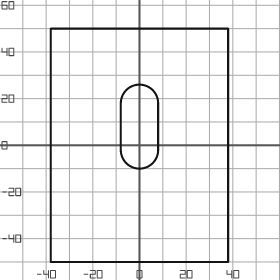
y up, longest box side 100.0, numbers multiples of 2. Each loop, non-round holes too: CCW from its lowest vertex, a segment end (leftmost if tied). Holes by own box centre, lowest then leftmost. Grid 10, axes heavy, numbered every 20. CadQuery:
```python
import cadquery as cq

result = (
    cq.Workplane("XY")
    .moveTo(-38.0, -50.0)
    .lineTo(38.0, -50.0)
    .lineTo(38.0, 50.0)
    .lineTo(-38.0, 50.0)
    .close()
    .moveTo(-8.0, -2.0)
    .threePointArc((0.0, -10.0), (8.0, -2.0))
    .lineTo(8.0, 18.0)
    .threePointArc((0.0, 26.0), (-8.0, 18.0))
    .close()
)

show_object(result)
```